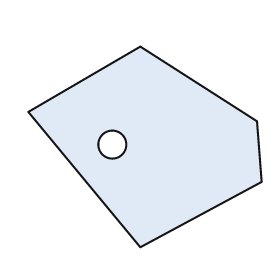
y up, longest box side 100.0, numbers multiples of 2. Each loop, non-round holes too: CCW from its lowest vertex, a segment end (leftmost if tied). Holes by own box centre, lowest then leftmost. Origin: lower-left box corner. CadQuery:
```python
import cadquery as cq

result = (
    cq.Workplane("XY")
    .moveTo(48.0, 0.0)
    .lineTo(100.0, 28.0)
    .lineTo(98.0, 54.0)
    .lineTo(48.0, 86.0)
    .lineTo(0.0, 58.0)
    .close()
    .moveTo(36.0, 44.0)
    .circle(6.0)
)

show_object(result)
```